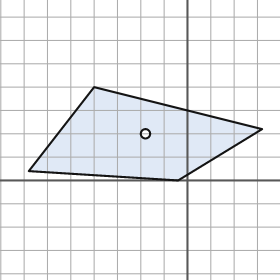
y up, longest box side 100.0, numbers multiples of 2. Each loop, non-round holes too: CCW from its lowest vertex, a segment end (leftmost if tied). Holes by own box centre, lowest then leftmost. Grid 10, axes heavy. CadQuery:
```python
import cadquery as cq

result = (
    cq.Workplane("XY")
    .moveTo(-4.0, 0.0)
    .lineTo(32.0, 22.0)
    .lineTo(-40.0, 40.0)
    .lineTo(-68.0, 4.0)
    .close()
    .moveTo(-18.0, 20.0)
    .circle(2.0)
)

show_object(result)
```